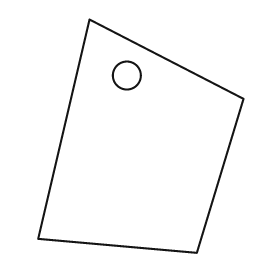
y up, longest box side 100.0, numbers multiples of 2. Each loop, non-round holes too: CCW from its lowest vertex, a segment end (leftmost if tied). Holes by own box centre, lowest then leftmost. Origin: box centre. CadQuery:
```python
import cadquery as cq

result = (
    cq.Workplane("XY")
    .moveTo(24.0, -50.0)
    .lineTo(44.0, 16.0)
    .lineTo(-22.0, 50.0)
    .lineTo(-44.0, -44.0)
    .close()
    .moveTo(-6.0, 26.0)
    .circle(6.0)
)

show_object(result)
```